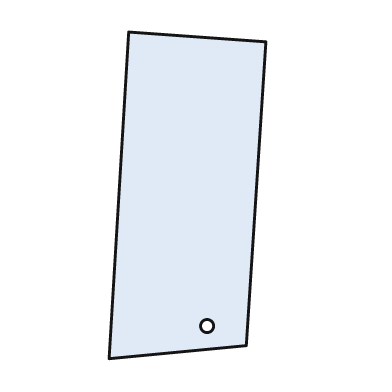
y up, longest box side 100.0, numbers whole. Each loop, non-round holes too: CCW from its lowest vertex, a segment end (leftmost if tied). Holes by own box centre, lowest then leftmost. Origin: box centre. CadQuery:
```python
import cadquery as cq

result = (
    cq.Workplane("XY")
    .moveTo(-24.0, -50.0)
    .lineTo(18.0, -46.0)
    .lineTo(24.0, 47.0)
    .lineTo(-18.0, 50.0)
    .close()
    .moveTo(6.0, -40.0)
    .circle(2.0)
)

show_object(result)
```